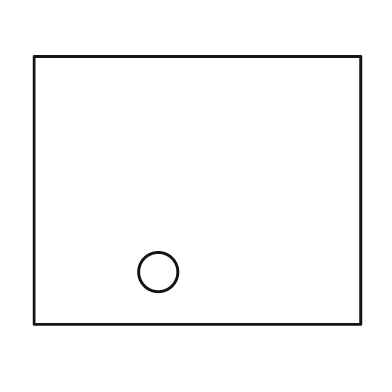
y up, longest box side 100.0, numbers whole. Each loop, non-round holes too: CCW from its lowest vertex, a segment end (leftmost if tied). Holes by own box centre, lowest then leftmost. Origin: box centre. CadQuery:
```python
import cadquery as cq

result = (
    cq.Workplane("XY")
    .moveTo(-50.0, -41.0)
    .lineTo(50.0, -41.0)
    .lineTo(50.0, 41.0)
    .lineTo(-50.0, 41.0)
    .close()
    .moveTo(-12.0, -25.0)
    .circle(6.0)
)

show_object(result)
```